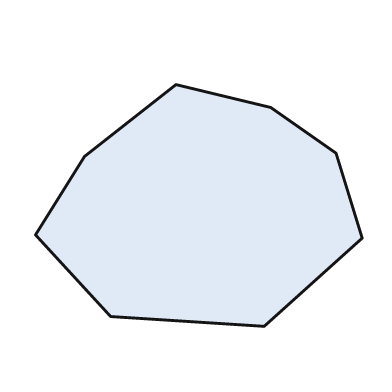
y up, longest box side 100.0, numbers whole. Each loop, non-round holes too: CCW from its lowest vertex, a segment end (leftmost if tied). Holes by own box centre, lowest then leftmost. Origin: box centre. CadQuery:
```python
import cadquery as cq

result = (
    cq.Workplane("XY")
    .moveTo(20.0, -37.0)
    .lineTo(50.0, -10.0)
    .lineTo(42.0, 16.0)
    .lineTo(22.0, 30.0)
    .lineTo(-7.0, 37.0)
    .lineTo(-35.0, 15.0)
    .lineTo(-50.0, -9.0)
    .lineTo(-27.0, -34.0)
    .close()
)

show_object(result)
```